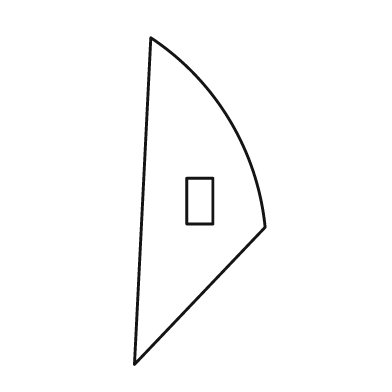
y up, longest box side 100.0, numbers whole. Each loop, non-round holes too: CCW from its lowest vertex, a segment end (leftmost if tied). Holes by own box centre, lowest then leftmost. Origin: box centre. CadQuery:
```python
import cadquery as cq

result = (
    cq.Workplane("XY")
    .moveTo(-20.0, -50.0)
    .lineTo(20.0, -8.0)
    .threePointArc((9.0, 25.0), (-15.0, 50.0))
    .close()
    .moveTo(-4.0, -7.0)
    .lineTo(4.0, -7.0)
    .lineTo(4.0, 7.0)
    .lineTo(-4.0, 7.0)
    .close()
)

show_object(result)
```